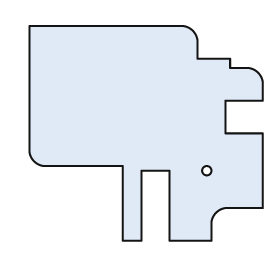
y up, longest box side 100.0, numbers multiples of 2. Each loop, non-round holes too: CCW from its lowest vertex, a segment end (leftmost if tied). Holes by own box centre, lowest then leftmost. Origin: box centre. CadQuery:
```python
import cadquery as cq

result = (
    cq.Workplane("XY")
    .moveTo(-10.0, -46.0)
    .lineTo(-2.0, -46.0)
    .lineTo(-2.0, -16.0)
    .lineTo(10.0, -16.0)
    .lineTo(10.0, -46.0)
    .lineTo(28.0, -46.0)
    .lineTo(28.0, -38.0)
    .threePointArc((30.0, -34.0), (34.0, -32.0))
    .lineTo(50.0, -32.0)
    .lineTo(50.0, 0.0)
    .lineTo(34.0, 0.0)
    .lineTo(34.0, 14.0)
    .lineTo(50.0, 14.0)
    .lineTo(50.0, 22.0)
    .threePointArc((48.0, 26.0), (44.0, 28.0))
    .lineTo(36.0, 28.0)
    .lineTo(36.0, 32.0)
    .lineTo(22.0, 32.0)
    .lineTo(22.0, 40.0)
    .threePointArc((20.0, 44.0), (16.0, 46.0))
    .lineTo(-50.0, 46.0)
    .lineTo(-50.0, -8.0)
    .threePointArc((-48.0, -12.0), (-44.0, -14.0))
    .lineTo(-10.0, -14.0)
    .close()
    .moveTo(26.0, -16.0)
    .circle(2.0)
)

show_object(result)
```